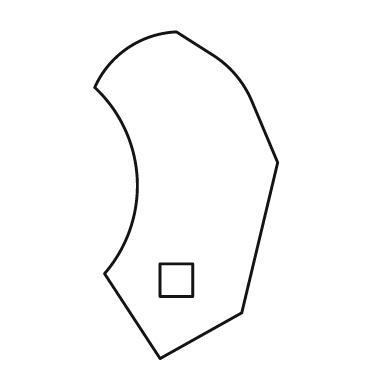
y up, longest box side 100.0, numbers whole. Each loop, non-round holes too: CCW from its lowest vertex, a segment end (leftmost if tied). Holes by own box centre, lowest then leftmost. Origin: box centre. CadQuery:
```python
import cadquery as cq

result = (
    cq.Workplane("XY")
    .moveTo(-8.0, -50.0)
    .lineTo(17.0, -36.0)
    .lineTo(28.0, 10.0)
    .lineTo(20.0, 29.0)
    .threePointArc((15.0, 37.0), (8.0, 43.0))
    .lineTo(-3.0, 50.0)
    .threePointArc((-18.0, 45.0), (-28.0, 33.0))
    .threePointArc((-15.0, 5.0), (-25.0, -24.0))
    .close()
    .moveTo(-8.0, -31.0)
    .lineTo(2.0, -31.0)
    .lineTo(2.0, -21.0)
    .lineTo(-8.0, -21.0)
    .close()
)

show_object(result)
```